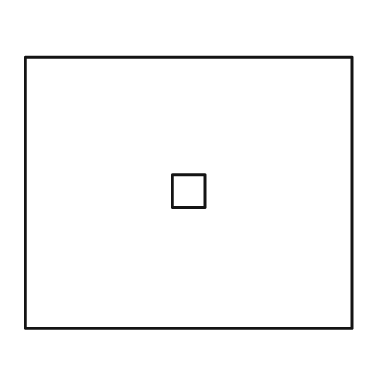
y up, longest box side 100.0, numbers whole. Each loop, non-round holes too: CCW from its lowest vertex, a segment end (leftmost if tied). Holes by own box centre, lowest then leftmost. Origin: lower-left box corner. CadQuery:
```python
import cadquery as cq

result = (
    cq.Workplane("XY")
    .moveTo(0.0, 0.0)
    .lineTo(100.0, 0.0)
    .lineTo(100.0, 83.0)
    .lineTo(0.0, 83.0)
    .close()
    .moveTo(45.0, 37.0)
    .lineTo(55.0, 37.0)
    .lineTo(55.0, 47.0)
    .lineTo(45.0, 47.0)
    .close()
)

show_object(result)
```